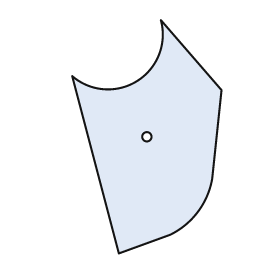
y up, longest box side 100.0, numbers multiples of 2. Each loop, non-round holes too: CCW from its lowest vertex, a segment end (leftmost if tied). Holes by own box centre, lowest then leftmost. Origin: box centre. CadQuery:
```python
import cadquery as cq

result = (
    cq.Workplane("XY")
    .moveTo(-12.0, -50.0)
    .lineTo(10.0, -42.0)
    .threePointArc((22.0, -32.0), (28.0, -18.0))
    .lineTo(32.0, 20.0)
    .lineTo(6.0, 50.0)
    .threePointArc((-4.0, 24.0), (-32.0, 26.0))
    .close()
    .moveTo(0.0, 0.0)
    .circle(2.0)
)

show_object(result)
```